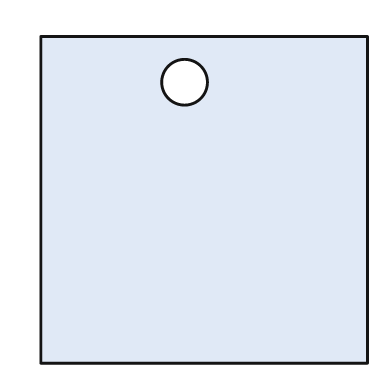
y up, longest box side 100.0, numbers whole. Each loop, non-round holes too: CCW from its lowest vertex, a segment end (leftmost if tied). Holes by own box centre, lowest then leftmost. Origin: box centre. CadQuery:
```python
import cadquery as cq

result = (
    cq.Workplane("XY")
    .moveTo(-50.0, -50.0)
    .lineTo(50.0, -50.0)
    .lineTo(50.0, 50.0)
    .lineTo(-50.0, 50.0)
    .close()
    .moveTo(-6.0, 36.0)
    .circle(7.0)
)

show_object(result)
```